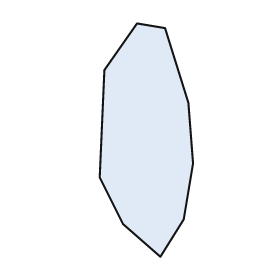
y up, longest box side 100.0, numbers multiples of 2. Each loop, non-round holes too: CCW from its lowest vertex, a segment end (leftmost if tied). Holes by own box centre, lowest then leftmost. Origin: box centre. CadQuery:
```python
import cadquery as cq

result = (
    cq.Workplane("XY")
    .moveTo(6.0, -50.0)
    .lineTo(16.0, -34.0)
    .lineTo(20.0, -10.0)
    .lineTo(18.0, 16.0)
    .lineTo(8.0, 48.0)
    .lineTo(-4.0, 50.0)
    .lineTo(-18.0, 30.0)
    .lineTo(-20.0, -16.0)
    .lineTo(-10.0, -36.0)
    .close()
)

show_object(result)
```